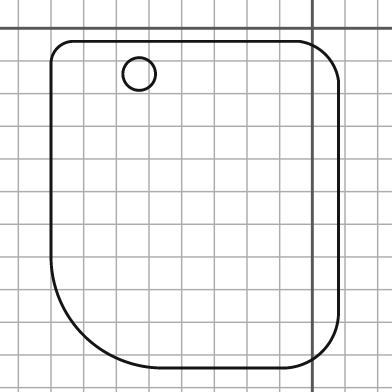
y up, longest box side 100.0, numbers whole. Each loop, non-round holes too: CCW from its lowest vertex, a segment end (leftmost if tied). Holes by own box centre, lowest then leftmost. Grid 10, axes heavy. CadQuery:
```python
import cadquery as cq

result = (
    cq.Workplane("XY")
    .moveTo(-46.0, -104.0)
    .lineTo(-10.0, -104.0)
    .threePointArc((3.0, -99.0), (8.0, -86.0))
    .lineTo(8.0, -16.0)
    .threePointArc((4.0, -8.0), (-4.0, -4.0))
    .lineTo(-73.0, -4.0)
    .threePointArc((-78.0, -6.0), (-80.0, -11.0))
    .lineTo(-80.0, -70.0)
    .threePointArc((-70.0, -94.0), (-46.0, -104.0))
    .close()
    .moveTo(-53.0, -14.0)
    .circle(5.0)
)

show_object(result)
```